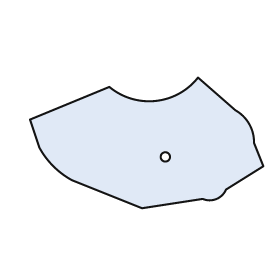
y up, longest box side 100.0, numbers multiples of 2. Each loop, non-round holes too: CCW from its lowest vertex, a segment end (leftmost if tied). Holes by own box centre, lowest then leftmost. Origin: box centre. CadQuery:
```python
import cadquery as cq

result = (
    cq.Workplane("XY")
    .moveTo(-2.0, -28.0)
    .lineTo(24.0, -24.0)
    .threePointArc((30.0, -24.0), (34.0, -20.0))
    .lineTo(50.0, -10.0)
    .lineTo(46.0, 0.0)
    .threePointArc((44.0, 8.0), (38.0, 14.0))
    .lineTo(22.0, 28.0)
    .threePointArc((4.0, 18.0), (-16.0, 24.0))
    .lineTo(-50.0, 10.0)
    .lineTo(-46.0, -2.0)
    .threePointArc((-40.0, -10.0), (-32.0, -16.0))
    .close()
    .moveTo(8.0, -6.0)
    .circle(2.0)
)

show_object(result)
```